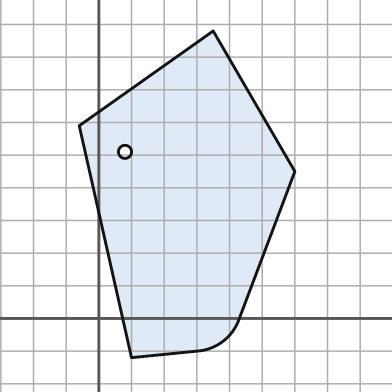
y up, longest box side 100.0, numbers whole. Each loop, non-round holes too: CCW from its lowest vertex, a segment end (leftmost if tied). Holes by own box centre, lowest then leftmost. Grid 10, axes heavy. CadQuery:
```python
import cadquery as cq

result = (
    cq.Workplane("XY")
    .moveTo(10.0, -12.0)
    .lineTo(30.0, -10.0)
    .threePointArc((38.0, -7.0), (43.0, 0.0))
    .lineTo(60.0, 45.0)
    .lineTo(35.0, 88.0)
    .lineTo(-6.0, 59.0)
    .close()
    .moveTo(8.0, 51.0)
    .circle(2.0)
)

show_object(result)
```